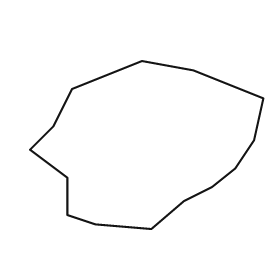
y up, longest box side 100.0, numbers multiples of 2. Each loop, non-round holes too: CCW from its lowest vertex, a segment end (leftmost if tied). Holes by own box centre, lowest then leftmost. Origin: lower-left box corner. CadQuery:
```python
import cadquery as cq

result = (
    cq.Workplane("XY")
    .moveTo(52.0, 0.0)
    .lineTo(66.0, 12.0)
    .lineTo(78.0, 18.0)
    .lineTo(88.0, 26.0)
    .lineTo(96.0, 38.0)
    .lineTo(100.0, 56.0)
    .lineTo(70.0, 68.0)
    .lineTo(48.0, 72.0)
    .lineTo(18.0, 60.0)
    .lineTo(10.0, 44.0)
    .lineTo(0.0, 34.0)
    .lineTo(16.0, 22.0)
    .lineTo(16.0, 6.0)
    .lineTo(28.0, 2.0)
    .close()
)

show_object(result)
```